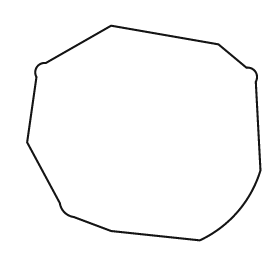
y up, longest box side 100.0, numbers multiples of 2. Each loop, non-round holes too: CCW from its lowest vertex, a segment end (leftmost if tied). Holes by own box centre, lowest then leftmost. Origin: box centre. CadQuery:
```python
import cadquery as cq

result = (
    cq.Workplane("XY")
    .moveTo(24.0, -46.0)
    .threePointArc((40.0, -34.0), (50.0, -16.0))
    .lineTo(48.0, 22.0)
    .threePointArc((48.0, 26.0), (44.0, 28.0))
    .lineTo(32.0, 38.0)
    .lineTo(-14.0, 46.0)
    .lineTo(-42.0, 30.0)
    .threePointArc((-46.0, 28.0), (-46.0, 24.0))
    .lineTo(-50.0, -4.0)
    .lineTo(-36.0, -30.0)
    .threePointArc((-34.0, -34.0), (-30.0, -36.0))
    .lineTo(-14.0, -42.0)
    .close()
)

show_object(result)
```